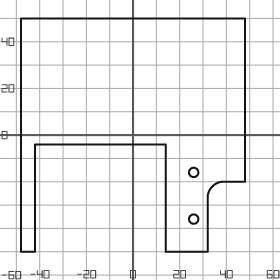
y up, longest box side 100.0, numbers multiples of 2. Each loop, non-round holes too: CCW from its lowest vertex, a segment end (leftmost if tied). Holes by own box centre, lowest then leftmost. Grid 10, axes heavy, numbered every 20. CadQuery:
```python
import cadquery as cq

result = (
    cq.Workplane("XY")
    .moveTo(-48.0, -50.0)
    .lineTo(-42.0, -50.0)
    .lineTo(-42.0, -4.0)
    .lineTo(14.0, -4.0)
    .lineTo(14.0, -50.0)
    .lineTo(32.0, -50.0)
    .lineTo(32.0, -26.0)
    .threePointArc((34.0, -22.0), (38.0, -20.0))
    .lineTo(48.0, -20.0)
    .lineTo(48.0, 50.0)
    .lineTo(-48.0, 50.0)
    .close()
    .moveTo(26.0, -36.0)
    .circle(2.0)
    .moveTo(26.0, -16.0)
    .circle(2.0)
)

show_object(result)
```